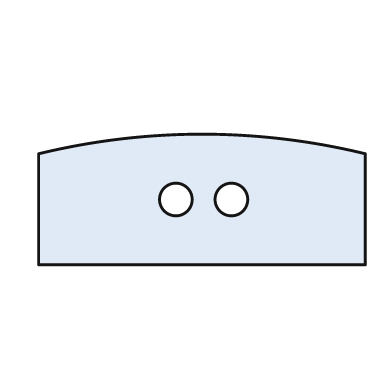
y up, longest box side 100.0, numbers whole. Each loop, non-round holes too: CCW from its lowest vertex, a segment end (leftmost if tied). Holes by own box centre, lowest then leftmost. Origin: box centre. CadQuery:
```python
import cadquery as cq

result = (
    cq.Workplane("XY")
    .moveTo(-50.0, -20.0)
    .lineTo(50.0, -20.0)
    .lineTo(50.0, 14.0)
    .threePointArc((0.0, 20.0), (-50.0, 14.0))
    .close()
    .moveTo(-8.0, 0.0)
    .circle(5.0)
    .moveTo(9.0, 0.0)
    .circle(5.0)
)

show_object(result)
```